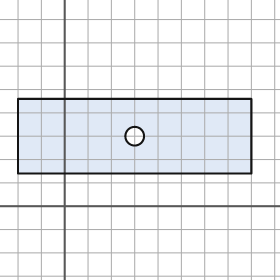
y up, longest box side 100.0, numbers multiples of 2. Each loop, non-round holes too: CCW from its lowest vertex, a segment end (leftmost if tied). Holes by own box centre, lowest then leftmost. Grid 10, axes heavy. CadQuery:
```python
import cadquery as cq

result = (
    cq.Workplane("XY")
    .moveTo(-20.0, 14.0)
    .lineTo(80.0, 14.0)
    .lineTo(80.0, 46.0)
    .lineTo(-20.0, 46.0)
    .close()
    .moveTo(30.0, 30.0)
    .circle(4.0)
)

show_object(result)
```